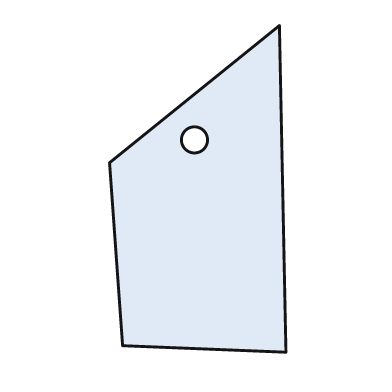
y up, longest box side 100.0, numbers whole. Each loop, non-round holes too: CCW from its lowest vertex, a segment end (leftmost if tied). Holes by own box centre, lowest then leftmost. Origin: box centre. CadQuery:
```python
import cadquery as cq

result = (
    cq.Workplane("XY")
    .moveTo(27.0, -50.0)
    .lineTo(25.0, 50.0)
    .lineTo(-27.0, 8.0)
    .lineTo(-23.0, -48.0)
    .close()
    .moveTo(-1.0, 15.0)
    .circle(4.0)
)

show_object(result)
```